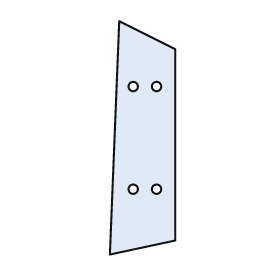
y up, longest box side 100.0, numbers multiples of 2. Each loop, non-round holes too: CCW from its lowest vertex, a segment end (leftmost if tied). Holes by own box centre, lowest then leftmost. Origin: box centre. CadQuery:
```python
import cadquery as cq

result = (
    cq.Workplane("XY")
    .moveTo(-14.0, -50.0)
    .lineTo(14.0, -44.0)
    .lineTo(14.0, 38.0)
    .lineTo(-10.0, 50.0)
    .close()
    .moveTo(-4.0, -22.0)
    .circle(2.0)
    .moveTo(6.0, -22.0)
    .circle(2.0)
    .moveTo(-4.0, 22.0)
    .circle(2.0)
    .moveTo(6.0, 22.0)
    .circle(2.0)
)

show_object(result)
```